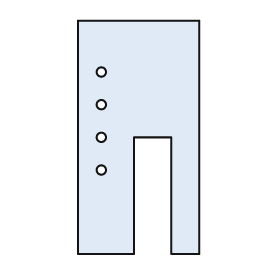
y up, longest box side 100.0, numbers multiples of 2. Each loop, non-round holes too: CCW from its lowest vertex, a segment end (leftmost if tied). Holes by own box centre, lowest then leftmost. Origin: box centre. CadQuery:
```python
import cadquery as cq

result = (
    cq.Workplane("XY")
    .moveTo(-26.0, -50.0)
    .lineTo(-2.0, -50.0)
    .lineTo(-2.0, 0.0)
    .lineTo(14.0, 0.0)
    .lineTo(14.0, -50.0)
    .lineTo(26.0, -50.0)
    .lineTo(26.0, 50.0)
    .lineTo(-26.0, 50.0)
    .close()
    .moveTo(-16.0, -14.0)
    .circle(2.0)
    .moveTo(-16.0, 0.0)
    .circle(2.0)
    .moveTo(-16.0, 14.0)
    .circle(2.0)
    .moveTo(-16.0, 28.0)
    .circle(2.0)
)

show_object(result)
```